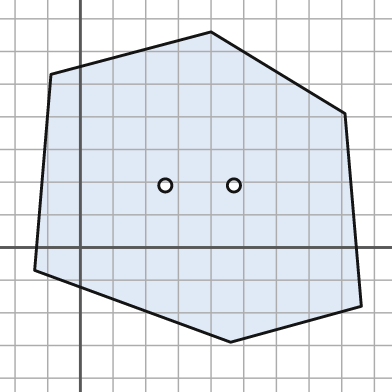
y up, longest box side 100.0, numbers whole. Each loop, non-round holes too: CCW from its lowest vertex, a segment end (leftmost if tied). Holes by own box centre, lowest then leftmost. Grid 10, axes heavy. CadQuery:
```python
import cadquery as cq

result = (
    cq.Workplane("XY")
    .moveTo(46.0, -29.0)
    .lineTo(86.0, -18.0)
    .lineTo(81.0, 41.0)
    .lineTo(40.0, 66.0)
    .lineTo(-9.0, 53.0)
    .lineTo(-14.0, -7.0)
    .close()
    .moveTo(26.0, 19.0)
    .circle(2.0)
    .moveTo(47.0, 19.0)
    .circle(2.0)
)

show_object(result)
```